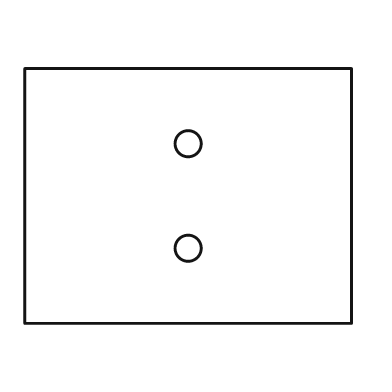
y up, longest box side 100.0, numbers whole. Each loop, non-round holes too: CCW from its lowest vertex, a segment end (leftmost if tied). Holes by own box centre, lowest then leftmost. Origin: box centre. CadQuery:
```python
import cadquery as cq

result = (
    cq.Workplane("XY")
    .moveTo(-50.0, -39.0)
    .lineTo(50.0, -39.0)
    .lineTo(50.0, 39.0)
    .lineTo(-50.0, 39.0)
    .close()
    .moveTo(0.0, -16.0)
    .circle(4.0)
    .moveTo(0.0, 16.0)
    .circle(4.0)
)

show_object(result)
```